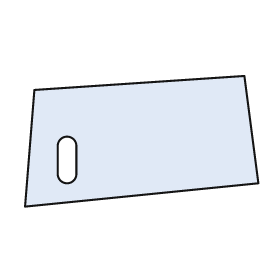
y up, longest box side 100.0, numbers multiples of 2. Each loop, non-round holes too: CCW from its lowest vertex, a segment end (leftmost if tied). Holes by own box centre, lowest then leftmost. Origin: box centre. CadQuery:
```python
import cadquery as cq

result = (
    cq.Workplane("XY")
    .moveTo(-50.0, -28.0)
    .lineTo(50.0, -18.0)
    .lineTo(44.0, 28.0)
    .lineTo(-46.0, 22.0)
    .close()
    .moveTo(-36.0, -14.0)
    .threePointArc((-32.0, -18.0), (-28.0, -14.0))
    .lineTo(-28.0, -2.0)
    .threePointArc((-32.0, 2.0), (-36.0, -2.0))
    .close()
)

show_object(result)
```